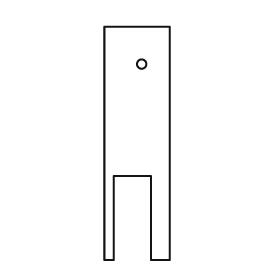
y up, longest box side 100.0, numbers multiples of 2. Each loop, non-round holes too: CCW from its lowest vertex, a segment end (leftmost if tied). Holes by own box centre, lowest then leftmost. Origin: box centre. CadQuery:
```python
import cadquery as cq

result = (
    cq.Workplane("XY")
    .moveTo(-14.0, -50.0)
    .lineTo(-10.0, -50.0)
    .lineTo(-10.0, -14.0)
    .lineTo(6.0, -14.0)
    .lineTo(6.0, -50.0)
    .lineTo(14.0, -50.0)
    .lineTo(14.0, 50.0)
    .lineTo(-14.0, 50.0)
    .close()
    .moveTo(2.0, 34.0)
    .circle(2.0)
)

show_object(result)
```